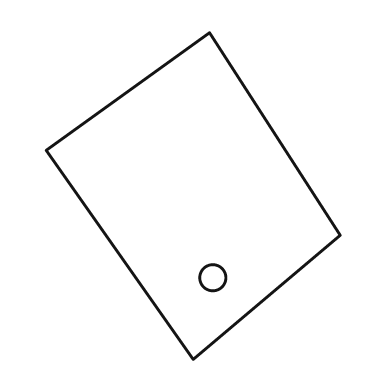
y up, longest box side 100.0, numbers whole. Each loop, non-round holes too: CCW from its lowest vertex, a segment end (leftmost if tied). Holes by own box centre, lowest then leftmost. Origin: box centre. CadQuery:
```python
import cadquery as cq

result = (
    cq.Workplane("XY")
    .moveTo(0.0, -50.0)
    .lineTo(45.0, -12.0)
    .lineTo(5.0, 50.0)
    .lineTo(-45.0, 14.0)
    .close()
    .moveTo(6.0, -25.0)
    .circle(4.0)
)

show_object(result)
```